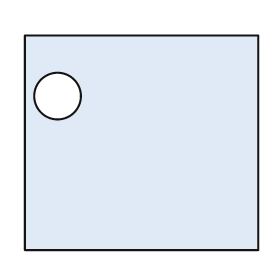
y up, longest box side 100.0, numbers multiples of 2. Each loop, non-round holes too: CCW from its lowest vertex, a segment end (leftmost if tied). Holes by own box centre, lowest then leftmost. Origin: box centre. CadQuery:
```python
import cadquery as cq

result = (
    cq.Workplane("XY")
    .moveTo(-50.0, -46.0)
    .lineTo(50.0, -46.0)
    .lineTo(50.0, 46.0)
    .lineTo(-50.0, 46.0)
    .close()
    .moveTo(-36.0, 20.0)
    .circle(10.0)
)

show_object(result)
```